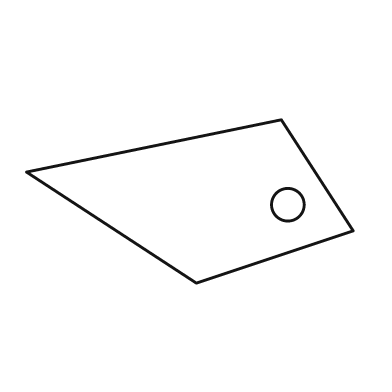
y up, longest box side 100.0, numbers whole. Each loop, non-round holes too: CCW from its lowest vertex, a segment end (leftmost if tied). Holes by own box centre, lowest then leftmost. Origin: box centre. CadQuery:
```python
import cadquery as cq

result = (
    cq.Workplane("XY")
    .moveTo(2.0, -25.0)
    .lineTo(50.0, -9.0)
    .lineTo(28.0, 25.0)
    .lineTo(-50.0, 9.0)
    .close()
    .moveTo(30.0, -1.0)
    .circle(5.0)
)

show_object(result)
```